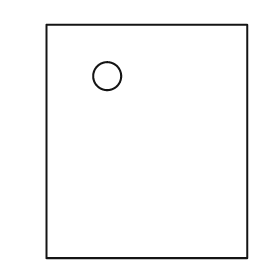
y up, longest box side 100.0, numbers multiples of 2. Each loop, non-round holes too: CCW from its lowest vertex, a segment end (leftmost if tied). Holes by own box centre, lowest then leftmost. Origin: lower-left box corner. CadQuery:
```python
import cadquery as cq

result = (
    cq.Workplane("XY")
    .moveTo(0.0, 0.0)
    .lineTo(86.0, 0.0)
    .lineTo(86.0, 100.0)
    .lineTo(0.0, 100.0)
    .close()
    .moveTo(26.0, 78.0)
    .circle(6.0)
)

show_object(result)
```